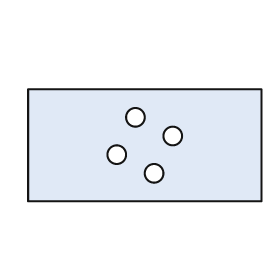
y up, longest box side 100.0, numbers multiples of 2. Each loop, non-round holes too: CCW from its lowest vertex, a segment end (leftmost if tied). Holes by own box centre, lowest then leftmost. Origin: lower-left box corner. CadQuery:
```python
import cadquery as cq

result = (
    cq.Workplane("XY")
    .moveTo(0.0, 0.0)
    .lineTo(100.0, 0.0)
    .lineTo(100.0, 48.0)
    .lineTo(0.0, 48.0)
    .close()
    .moveTo(54.0, 12.0)
    .circle(4.0)
    .moveTo(38.0, 20.0)
    .circle(4.0)
    .moveTo(62.0, 28.0)
    .circle(4.0)
    .moveTo(46.0, 36.0)
    .circle(4.0)
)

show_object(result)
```